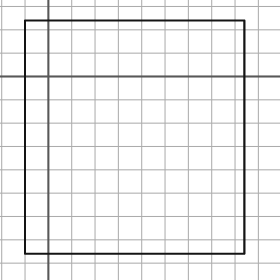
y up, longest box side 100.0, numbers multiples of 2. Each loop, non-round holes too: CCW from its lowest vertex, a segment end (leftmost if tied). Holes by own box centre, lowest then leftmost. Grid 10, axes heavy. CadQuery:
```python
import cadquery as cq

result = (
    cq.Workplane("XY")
    .moveTo(-10.0, -76.0)
    .lineTo(84.0, -76.0)
    .lineTo(84.0, 24.0)
    .lineTo(-10.0, 24.0)
    .close()
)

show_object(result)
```